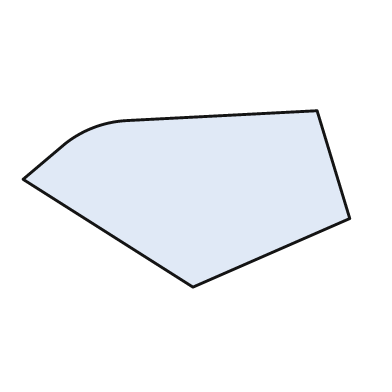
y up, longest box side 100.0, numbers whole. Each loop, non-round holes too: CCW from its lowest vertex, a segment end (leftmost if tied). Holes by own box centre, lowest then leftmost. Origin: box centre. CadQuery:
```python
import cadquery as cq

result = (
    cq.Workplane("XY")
    .moveTo(2.0, -27.0)
    .lineTo(50.0, -6.0)
    .lineTo(40.0, 27.0)
    .lineTo(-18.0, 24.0)
    .threePointArc((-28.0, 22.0), (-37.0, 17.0))
    .lineTo(-50.0, 6.0)
    .close()
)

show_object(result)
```